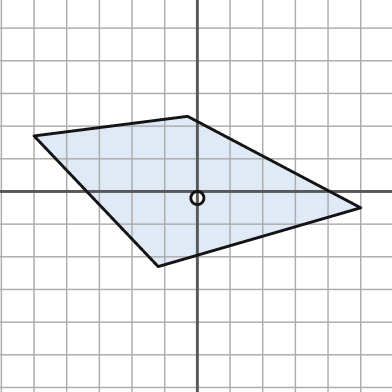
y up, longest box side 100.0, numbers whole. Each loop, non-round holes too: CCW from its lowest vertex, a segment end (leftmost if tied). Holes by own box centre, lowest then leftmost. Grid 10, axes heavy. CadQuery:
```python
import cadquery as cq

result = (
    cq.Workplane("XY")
    .moveTo(-12.0, -23.0)
    .lineTo(50.0, -5.0)
    .lineTo(-3.0, 23.0)
    .lineTo(-50.0, 17.0)
    .close()
    .moveTo(0.0, -2.0)
    .circle(2.0)
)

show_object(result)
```